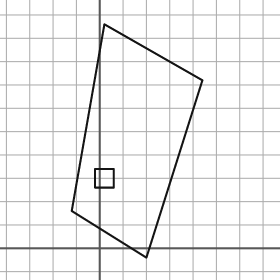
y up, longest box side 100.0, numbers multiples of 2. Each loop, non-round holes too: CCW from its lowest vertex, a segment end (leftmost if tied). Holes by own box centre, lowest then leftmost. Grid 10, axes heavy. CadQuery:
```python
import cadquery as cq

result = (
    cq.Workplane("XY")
    .moveTo(20.0, -4.0)
    .lineTo(44.0, 72.0)
    .lineTo(2.0, 96.0)
    .lineTo(-12.0, 16.0)
    .close()
    .moveTo(-2.0, 26.0)
    .lineTo(6.0, 26.0)
    .lineTo(6.0, 34.0)
    .lineTo(-2.0, 34.0)
    .close()
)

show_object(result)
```